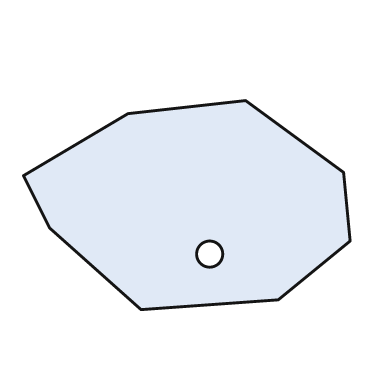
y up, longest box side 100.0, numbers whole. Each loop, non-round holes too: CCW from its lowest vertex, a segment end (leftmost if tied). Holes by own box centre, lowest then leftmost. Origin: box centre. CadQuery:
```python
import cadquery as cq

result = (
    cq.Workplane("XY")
    .moveTo(-14.0, -32.0)
    .lineTo(28.0, -29.0)
    .lineTo(50.0, -11.0)
    .lineTo(48.0, 10.0)
    .lineTo(18.0, 32.0)
    .lineTo(-18.0, 28.0)
    .lineTo(-50.0, 9.0)
    .lineTo(-42.0, -7.0)
    .close()
    .moveTo(7.0, -15.0)
    .circle(4.0)
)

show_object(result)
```